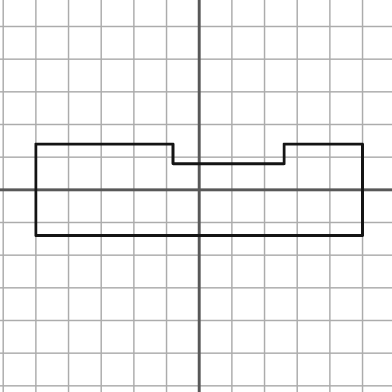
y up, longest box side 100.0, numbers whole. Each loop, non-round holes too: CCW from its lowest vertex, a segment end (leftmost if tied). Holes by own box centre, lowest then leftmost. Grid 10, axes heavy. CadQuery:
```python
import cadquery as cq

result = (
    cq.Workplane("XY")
    .moveTo(-50.0, -14.0)
    .lineTo(50.0, -14.0)
    .lineTo(50.0, 14.0)
    .lineTo(26.0, 14.0)
    .lineTo(26.0, 8.0)
    .lineTo(-8.0, 8.0)
    .lineTo(-8.0, 14.0)
    .lineTo(-50.0, 14.0)
    .close()
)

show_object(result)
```